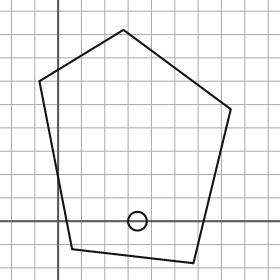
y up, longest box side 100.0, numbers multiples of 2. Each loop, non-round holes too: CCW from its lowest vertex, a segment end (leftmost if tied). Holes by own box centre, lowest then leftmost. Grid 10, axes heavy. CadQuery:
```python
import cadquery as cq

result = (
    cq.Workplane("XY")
    .moveTo(58.0, -18.0)
    .lineTo(74.0, 48.0)
    .lineTo(28.0, 82.0)
    .lineTo(-8.0, 60.0)
    .lineTo(6.0, -12.0)
    .close()
    .moveTo(34.0, 0.0)
    .circle(4.0)
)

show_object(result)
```